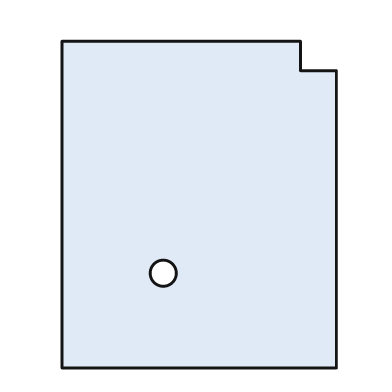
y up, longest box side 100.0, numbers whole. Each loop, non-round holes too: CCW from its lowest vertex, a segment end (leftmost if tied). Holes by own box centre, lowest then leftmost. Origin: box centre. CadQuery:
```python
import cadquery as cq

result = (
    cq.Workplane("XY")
    .moveTo(-42.0, -50.0)
    .lineTo(42.0, -50.0)
    .lineTo(42.0, 41.0)
    .lineTo(31.0, 41.0)
    .lineTo(31.0, 50.0)
    .lineTo(-42.0, 50.0)
    .close()
    .moveTo(-11.0, -21.0)
    .circle(4.0)
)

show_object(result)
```